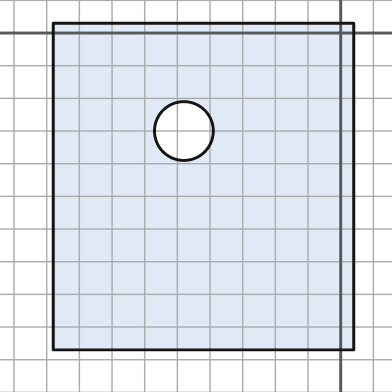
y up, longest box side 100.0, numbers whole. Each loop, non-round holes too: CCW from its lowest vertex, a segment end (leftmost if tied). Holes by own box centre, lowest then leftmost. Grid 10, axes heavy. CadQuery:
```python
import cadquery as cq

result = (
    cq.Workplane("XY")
    .moveTo(-88.0, -97.0)
    .lineTo(4.0, -97.0)
    .lineTo(4.0, 3.0)
    .lineTo(-88.0, 3.0)
    .close()
    .moveTo(-48.0, -30.0)
    .circle(9.0)
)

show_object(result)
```